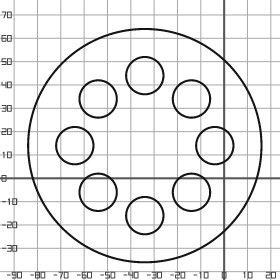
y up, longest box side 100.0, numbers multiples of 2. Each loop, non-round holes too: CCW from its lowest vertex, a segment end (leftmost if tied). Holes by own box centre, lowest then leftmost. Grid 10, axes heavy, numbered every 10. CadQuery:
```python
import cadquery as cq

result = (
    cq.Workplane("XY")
    .moveTo(-34.0, 14.0)
    .circle(50.0)
    .moveTo(-34.0, -16.0)
    .circle(8.0)
    .moveTo(-54.0, -6.0)
    .circle(8.0)
    .moveTo(-14.0, -6.0)
    .circle(8.0)
    .moveTo(-64.0, 14.0)
    .circle(8.0)
    .moveTo(-4.0, 14.0)
    .circle(8.0)
    .moveTo(-54.0, 34.0)
    .circle(8.0)
    .moveTo(-14.0, 34.0)
    .circle(8.0)
    .moveTo(-34.0, 44.0)
    .circle(8.0)
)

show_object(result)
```